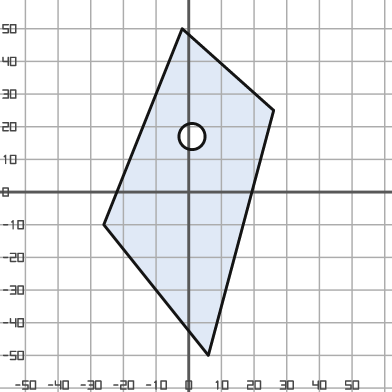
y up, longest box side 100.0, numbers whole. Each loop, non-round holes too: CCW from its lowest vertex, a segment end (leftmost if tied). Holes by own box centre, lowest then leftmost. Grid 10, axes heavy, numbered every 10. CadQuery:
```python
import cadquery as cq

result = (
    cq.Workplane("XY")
    .moveTo(6.0, -50.0)
    .lineTo(26.0, 25.0)
    .lineTo(-2.0, 50.0)
    .lineTo(-26.0, -10.0)
    .close()
    .moveTo(1.0, 17.0)
    .circle(4.0)
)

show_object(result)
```